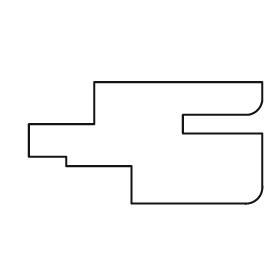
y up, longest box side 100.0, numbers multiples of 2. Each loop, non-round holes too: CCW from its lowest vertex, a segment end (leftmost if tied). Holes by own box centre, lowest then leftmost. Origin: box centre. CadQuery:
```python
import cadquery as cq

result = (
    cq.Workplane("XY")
    .moveTo(-6.0, -26.0)
    .lineTo(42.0, -26.0)
    .threePointArc((48.0, -24.0), (50.0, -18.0))
    .lineTo(50.0, 4.0)
    .lineTo(16.0, 4.0)
    .lineTo(16.0, 12.0)
    .lineTo(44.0, 12.0)
    .threePointArc((48.0, 14.0), (50.0, 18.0))
    .lineTo(50.0, 26.0)
    .lineTo(-22.0, 26.0)
    .lineTo(-22.0, 8.0)
    .lineTo(-50.0, 8.0)
    .lineTo(-50.0, -6.0)
    .lineTo(-34.0, -6.0)
    .lineTo(-34.0, -10.0)
    .lineTo(-6.0, -10.0)
    .close()
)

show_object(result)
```